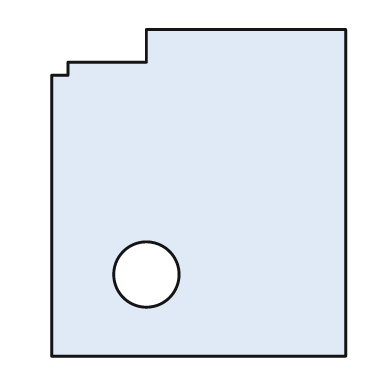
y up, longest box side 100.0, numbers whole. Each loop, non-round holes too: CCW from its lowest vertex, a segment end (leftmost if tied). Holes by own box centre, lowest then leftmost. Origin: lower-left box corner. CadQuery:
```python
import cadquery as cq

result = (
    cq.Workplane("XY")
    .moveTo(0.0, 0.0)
    .lineTo(90.0, 0.0)
    .lineTo(90.0, 100.0)
    .lineTo(29.0, 100.0)
    .lineTo(29.0, 90.0)
    .lineTo(5.0, 90.0)
    .lineTo(5.0, 86.0)
    .lineTo(0.0, 86.0)
    .close()
    .moveTo(29.0, 25.0)
    .circle(10.0)
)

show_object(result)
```